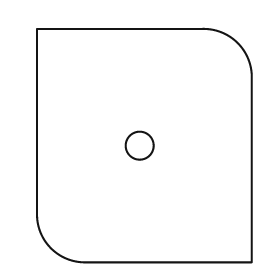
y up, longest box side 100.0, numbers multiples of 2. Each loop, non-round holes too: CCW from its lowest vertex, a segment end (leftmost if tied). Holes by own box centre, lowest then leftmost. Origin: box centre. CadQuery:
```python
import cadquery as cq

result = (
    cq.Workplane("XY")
    .moveTo(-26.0, -50.0)
    .lineTo(46.0, -50.0)
    .lineTo(46.0, 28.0)
    .threePointArc((40.0, 44.0), (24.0, 50.0))
    .lineTo(-46.0, 50.0)
    .lineTo(-46.0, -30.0)
    .threePointArc((-40.0, -44.0), (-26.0, -50.0))
    .close()
    .moveTo(-2.0, 0.0)
    .circle(6.0)
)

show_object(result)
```